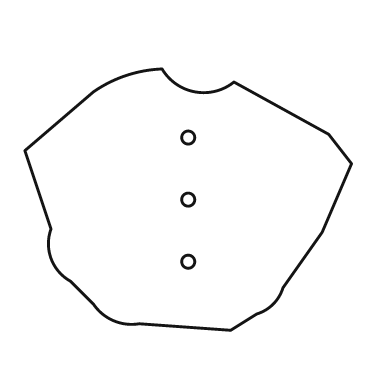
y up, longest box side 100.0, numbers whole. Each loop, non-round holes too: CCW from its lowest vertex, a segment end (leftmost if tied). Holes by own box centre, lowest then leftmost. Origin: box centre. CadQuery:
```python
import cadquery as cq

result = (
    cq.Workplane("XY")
    .moveTo(13.0, -40.0)
    .lineTo(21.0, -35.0)
    .threePointArc((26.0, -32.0), (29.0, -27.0))
    .lineTo(41.0, -10.0)
    .lineTo(50.0, 11.0)
    .lineTo(43.0, 20.0)
    .lineTo(14.0, 36.0)
    .threePointArc((2.0, 33.0), (-8.0, 40.0))
    .threePointArc((-19.0, 38.0), (-29.0, 33.0))
    .lineTo(-50.0, 15.0)
    .lineTo(-42.0, -9.0)
    .threePointArc((-42.0, -18.0), (-36.0, -25.0))
    .lineTo(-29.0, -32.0)
    .threePointArc((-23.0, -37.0), (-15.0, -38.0))
    .close()
    .moveTo(0.0, -19.0)
    .circle(2.0)
    .moveTo(0.0, 0.0)
    .circle(2.0)
    .moveTo(0.0, 19.0)
    .circle(2.0)
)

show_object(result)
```